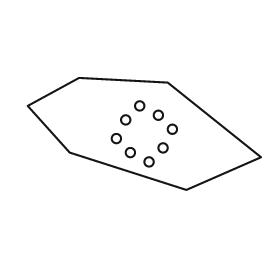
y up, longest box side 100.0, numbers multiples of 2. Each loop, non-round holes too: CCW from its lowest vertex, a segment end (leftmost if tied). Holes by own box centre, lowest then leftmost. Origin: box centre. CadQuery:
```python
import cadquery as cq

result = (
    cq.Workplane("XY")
    .moveTo(18.0, -24.0)
    .lineTo(50.0, -10.0)
    .lineTo(10.0, 22.0)
    .lineTo(-28.0, 24.0)
    .lineTo(-50.0, 12.0)
    .lineTo(-32.0, -8.0)
    .close()
    .moveTo(2.0, -12.0)
    .circle(2.0)
    .moveTo(-6.0, -8.0)
    .circle(2.0)
    .moveTo(8.0, -6.0)
    .circle(2.0)
    .moveTo(-12.0, -2.0)
    .circle(2.0)
    .moveTo(12.0, 2.0)
    .circle(2.0)
    .moveTo(-8.0, 6.0)
    .circle(2.0)
    .moveTo(6.0, 8.0)
    .circle(2.0)
    .moveTo(-2.0, 12.0)
    .circle(2.0)
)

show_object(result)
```